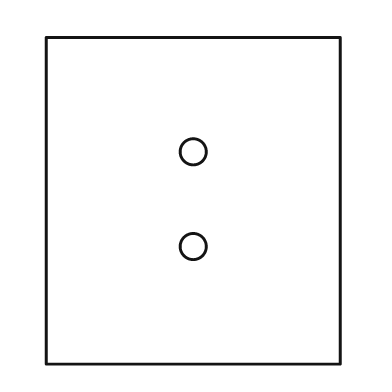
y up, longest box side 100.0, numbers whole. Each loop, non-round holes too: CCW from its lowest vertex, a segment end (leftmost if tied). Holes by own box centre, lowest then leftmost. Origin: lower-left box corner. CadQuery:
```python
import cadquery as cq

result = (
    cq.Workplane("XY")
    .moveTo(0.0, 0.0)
    .lineTo(90.0, 0.0)
    .lineTo(90.0, 100.0)
    .lineTo(0.0, 100.0)
    .close()
    .moveTo(45.0, 36.0)
    .circle(4.0)
    .moveTo(45.0, 65.0)
    .circle(4.0)
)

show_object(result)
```